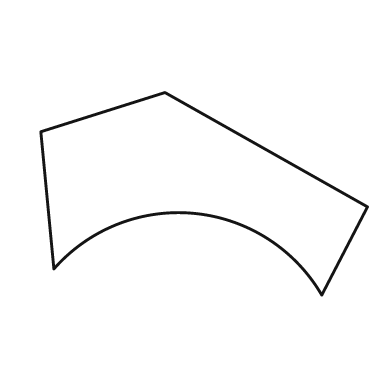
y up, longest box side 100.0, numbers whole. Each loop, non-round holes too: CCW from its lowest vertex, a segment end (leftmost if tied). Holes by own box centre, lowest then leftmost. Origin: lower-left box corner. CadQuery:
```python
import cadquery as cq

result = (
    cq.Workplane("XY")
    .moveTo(86.0, 0.0)
    .lineTo(100.0, 27.0)
    .lineTo(38.0, 62.0)
    .lineTo(0.0, 50.0)
    .lineTo(4.0, 8.0)
    .threePointArc((47.0, 25.0), (86.0, 0.0))
    .close()
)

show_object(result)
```